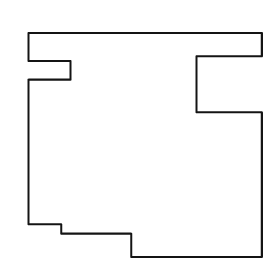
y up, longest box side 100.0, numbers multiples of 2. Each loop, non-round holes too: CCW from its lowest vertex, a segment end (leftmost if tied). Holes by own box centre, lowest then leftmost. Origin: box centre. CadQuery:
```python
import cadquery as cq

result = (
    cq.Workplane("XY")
    .moveTo(-6.0, -48.0)
    .lineTo(50.0, -48.0)
    .lineTo(50.0, 14.0)
    .lineTo(22.0, 14.0)
    .lineTo(22.0, 38.0)
    .lineTo(50.0, 38.0)
    .lineTo(50.0, 48.0)
    .lineTo(-50.0, 48.0)
    .lineTo(-50.0, 36.0)
    .lineTo(-32.0, 36.0)
    .lineTo(-32.0, 28.0)
    .lineTo(-50.0, 28.0)
    .lineTo(-50.0, -34.0)
    .lineTo(-36.0, -34.0)
    .lineTo(-36.0, -38.0)
    .lineTo(-6.0, -38.0)
    .close()
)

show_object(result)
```